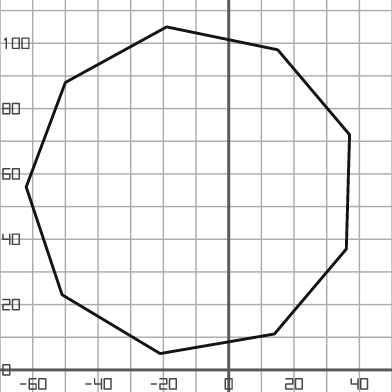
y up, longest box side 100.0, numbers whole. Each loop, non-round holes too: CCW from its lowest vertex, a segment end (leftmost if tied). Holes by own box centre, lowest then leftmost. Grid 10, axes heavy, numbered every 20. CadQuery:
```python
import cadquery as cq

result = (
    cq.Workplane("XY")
    .moveTo(-21.0, 5.0)
    .lineTo(14.0, 11.0)
    .lineTo(36.0, 37.0)
    .lineTo(37.0, 72.0)
    .lineTo(15.0, 98.0)
    .lineTo(-19.0, 105.0)
    .lineTo(-50.0, 88.0)
    .lineTo(-62.0, 56.0)
    .lineTo(-51.0, 23.0)
    .close()
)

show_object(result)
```